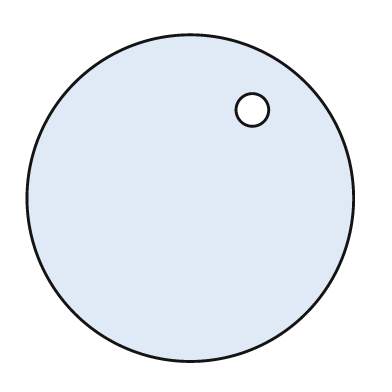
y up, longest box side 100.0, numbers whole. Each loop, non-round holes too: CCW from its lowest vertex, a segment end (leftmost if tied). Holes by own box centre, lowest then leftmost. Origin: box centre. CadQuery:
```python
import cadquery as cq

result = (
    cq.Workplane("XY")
    .moveTo(0.0, 0.0)
    .circle(50.0)
    .moveTo(19.0, 27.0)
    .circle(5.0)
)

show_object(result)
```